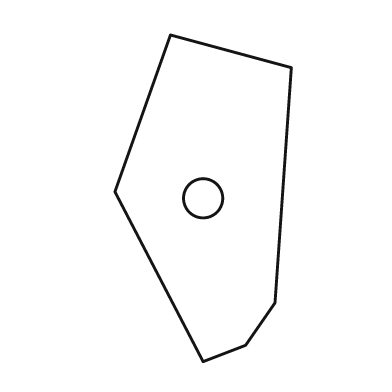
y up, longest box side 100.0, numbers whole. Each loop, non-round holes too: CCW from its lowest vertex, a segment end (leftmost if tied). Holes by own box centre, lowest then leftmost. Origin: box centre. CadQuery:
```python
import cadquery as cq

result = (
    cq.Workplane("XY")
    .moveTo(0.0, -50.0)
    .lineTo(13.0, -45.0)
    .lineTo(22.0, -32.0)
    .lineTo(27.0, 40.0)
    .lineTo(-10.0, 50.0)
    .lineTo(-27.0, 2.0)
    .close()
    .moveTo(0.0, 0.0)
    .circle(6.0)
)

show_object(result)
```